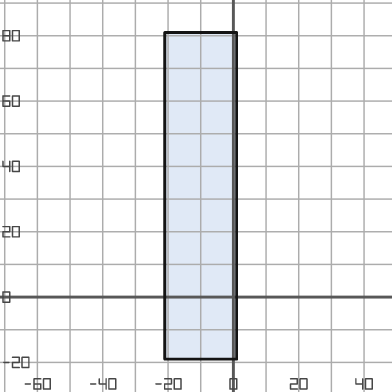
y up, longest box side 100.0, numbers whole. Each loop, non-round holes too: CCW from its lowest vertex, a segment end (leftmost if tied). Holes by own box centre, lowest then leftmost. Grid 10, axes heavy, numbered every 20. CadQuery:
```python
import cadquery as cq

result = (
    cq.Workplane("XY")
    .moveTo(-21.0, -19.0)
    .lineTo(1.0, -19.0)
    .lineTo(1.0, 81.0)
    .lineTo(-21.0, 81.0)
    .close()
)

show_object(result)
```